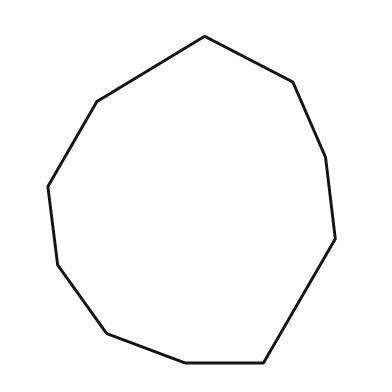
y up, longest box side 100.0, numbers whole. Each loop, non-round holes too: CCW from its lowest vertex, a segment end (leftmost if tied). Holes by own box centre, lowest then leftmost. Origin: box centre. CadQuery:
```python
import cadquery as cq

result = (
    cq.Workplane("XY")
    .moveTo(-2.0, -50.0)
    .lineTo(22.0, -50.0)
    .lineTo(44.0, -12.0)
    .lineTo(41.0, 13.0)
    .lineTo(31.0, 36.0)
    .lineTo(4.0, 50.0)
    .lineTo(-29.0, 30.0)
    .lineTo(-44.0, 4.0)
    .lineTo(-41.0, -20.0)
    .lineTo(-26.0, -41.0)
    .close()
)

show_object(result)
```